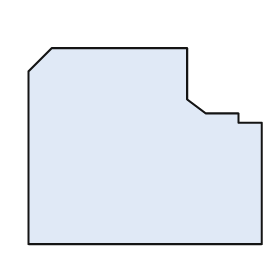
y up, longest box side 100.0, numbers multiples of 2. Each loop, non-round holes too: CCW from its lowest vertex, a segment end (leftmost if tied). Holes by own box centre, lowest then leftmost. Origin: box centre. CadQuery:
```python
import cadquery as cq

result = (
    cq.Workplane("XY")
    .moveTo(-50.0, -42.0)
    .lineTo(50.0, -42.0)
    .lineTo(50.0, 10.0)
    .lineTo(40.0, 10.0)
    .lineTo(40.0, 14.0)
    .lineTo(26.0, 14.0)
    .lineTo(18.0, 20.0)
    .lineTo(18.0, 42.0)
    .lineTo(-40.0, 42.0)
    .lineTo(-50.0, 32.0)
    .close()
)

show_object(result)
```